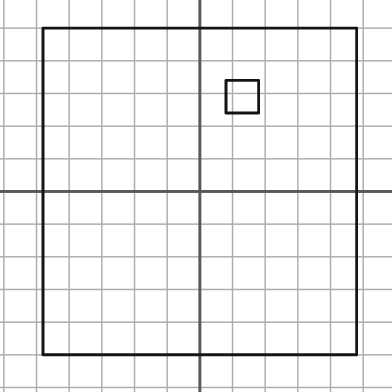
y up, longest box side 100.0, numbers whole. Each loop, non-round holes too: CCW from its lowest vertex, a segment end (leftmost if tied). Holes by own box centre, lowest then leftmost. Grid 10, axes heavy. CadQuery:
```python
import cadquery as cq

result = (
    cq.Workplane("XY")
    .moveTo(-48.0, -50.0)
    .lineTo(48.0, -50.0)
    .lineTo(48.0, 50.0)
    .lineTo(-48.0, 50.0)
    .close()
    .moveTo(8.0, 24.0)
    .lineTo(18.0, 24.0)
    .lineTo(18.0, 34.0)
    .lineTo(8.0, 34.0)
    .close()
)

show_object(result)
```